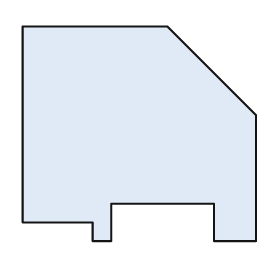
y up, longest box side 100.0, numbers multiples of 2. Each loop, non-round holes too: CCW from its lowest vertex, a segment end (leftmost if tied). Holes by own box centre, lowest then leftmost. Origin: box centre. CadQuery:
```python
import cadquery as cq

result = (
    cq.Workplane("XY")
    .moveTo(-20.0, -46.0)
    .lineTo(-12.0, -46.0)
    .lineTo(-12.0, -30.0)
    .lineTo(32.0, -30.0)
    .lineTo(32.0, -46.0)
    .lineTo(50.0, -46.0)
    .lineTo(50.0, 8.0)
    .lineTo(12.0, 46.0)
    .lineTo(-50.0, 46.0)
    .lineTo(-50.0, -38.0)
    .lineTo(-20.0, -38.0)
    .close()
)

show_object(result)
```